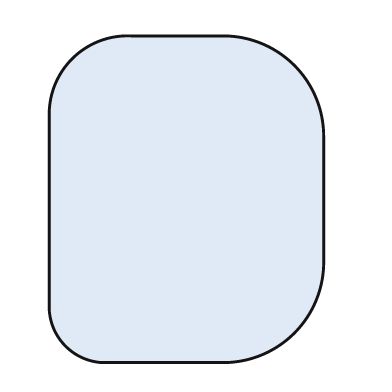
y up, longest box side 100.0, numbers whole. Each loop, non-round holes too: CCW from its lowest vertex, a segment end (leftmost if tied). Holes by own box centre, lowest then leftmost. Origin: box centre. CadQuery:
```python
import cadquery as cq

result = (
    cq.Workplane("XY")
    .moveTo(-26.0, -50.0)
    .lineTo(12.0, -50.0)
    .threePointArc((33.0, -41.0), (42.0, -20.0))
    .lineTo(42.0, 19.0)
    .threePointArc((33.0, 41.0), (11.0, 50.0))
    .lineTo(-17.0, 50.0)
    .threePointArc((-35.0, 43.0), (-42.0, 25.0))
    .lineTo(-42.0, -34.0)
    .threePointArc((-37.0, -45.0), (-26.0, -50.0))
    .close()
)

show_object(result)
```